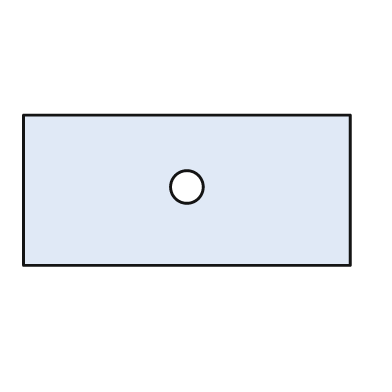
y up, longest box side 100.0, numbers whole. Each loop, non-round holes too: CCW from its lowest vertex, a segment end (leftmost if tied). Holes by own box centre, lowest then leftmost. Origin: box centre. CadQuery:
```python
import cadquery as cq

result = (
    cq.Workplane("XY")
    .moveTo(-50.0, -23.0)
    .lineTo(50.0, -23.0)
    .lineTo(50.0, 23.0)
    .lineTo(-50.0, 23.0)
    .close()
    .moveTo(0.0, 1.0)
    .circle(5.0)
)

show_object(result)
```